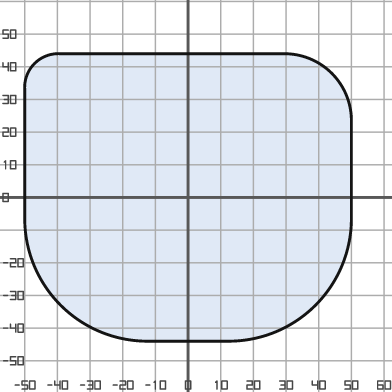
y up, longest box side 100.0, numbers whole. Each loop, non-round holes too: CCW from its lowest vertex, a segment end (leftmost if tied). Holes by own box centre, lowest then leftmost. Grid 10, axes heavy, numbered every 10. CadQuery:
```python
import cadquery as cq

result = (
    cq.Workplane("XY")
    .moveTo(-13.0, -44.0)
    .lineTo(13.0, -44.0)
    .threePointArc((39.0, -33.0), (50.0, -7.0))
    .lineTo(50.0, 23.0)
    .threePointArc((44.0, 38.0), (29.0, 44.0))
    .lineTo(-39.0, 44.0)
    .threePointArc((-47.0, 41.0), (-50.0, 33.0))
    .lineTo(-50.0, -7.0)
    .threePointArc((-39.0, -33.0), (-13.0, -44.0))
    .close()
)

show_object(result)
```